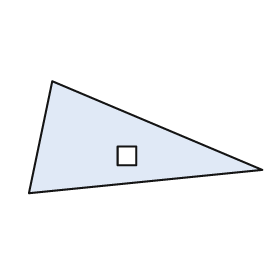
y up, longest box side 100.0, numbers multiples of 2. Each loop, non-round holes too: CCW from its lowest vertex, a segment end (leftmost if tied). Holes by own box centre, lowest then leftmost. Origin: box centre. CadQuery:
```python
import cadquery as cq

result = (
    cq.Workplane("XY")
    .moveTo(-50.0, -24.0)
    .lineTo(50.0, -14.0)
    .lineTo(-40.0, 24.0)
    .close()
    .moveTo(-12.0, -12.0)
    .lineTo(-4.0, -12.0)
    .lineTo(-4.0, -4.0)
    .lineTo(-12.0, -4.0)
    .close()
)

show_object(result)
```